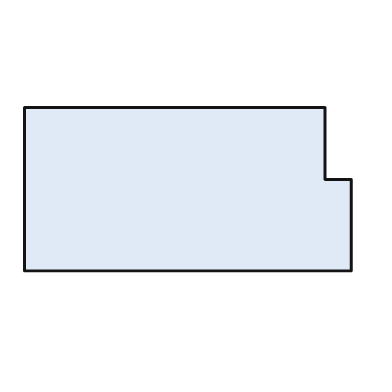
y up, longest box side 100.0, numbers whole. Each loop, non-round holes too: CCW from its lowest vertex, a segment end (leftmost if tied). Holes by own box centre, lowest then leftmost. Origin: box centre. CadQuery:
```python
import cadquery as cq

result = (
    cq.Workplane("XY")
    .moveTo(-50.0, -25.0)
    .lineTo(50.0, -25.0)
    .lineTo(50.0, 3.0)
    .lineTo(42.0, 3.0)
    .lineTo(42.0, 25.0)
    .lineTo(-50.0, 25.0)
    .close()
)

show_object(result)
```